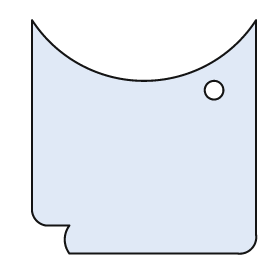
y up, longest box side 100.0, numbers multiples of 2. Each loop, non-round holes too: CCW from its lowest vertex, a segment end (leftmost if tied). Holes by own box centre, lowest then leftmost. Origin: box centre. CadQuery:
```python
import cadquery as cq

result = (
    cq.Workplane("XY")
    .moveTo(-32.0, -50.0)
    .lineTo(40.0, -50.0)
    .threePointArc((46.0, -48.0), (48.0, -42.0))
    .lineTo(48.0, 50.0)
    .threePointArc((0.0, 24.0), (-48.0, 50.0))
    .lineTo(-48.0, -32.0)
    .threePointArc((-46.0, -36.0), (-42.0, -38.0))
    .lineTo(-32.0, -38.0)
    .threePointArc((-34.0, -44.0), (-32.0, -50.0))
    .close()
    .moveTo(30.0, 20.0)
    .circle(4.0)
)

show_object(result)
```